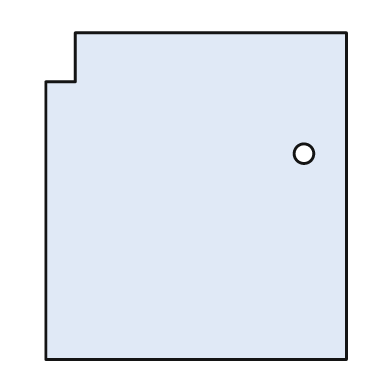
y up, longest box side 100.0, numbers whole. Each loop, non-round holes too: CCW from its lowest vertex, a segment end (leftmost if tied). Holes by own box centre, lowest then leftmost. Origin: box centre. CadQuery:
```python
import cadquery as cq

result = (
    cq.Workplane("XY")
    .moveTo(-46.0, -50.0)
    .lineTo(46.0, -50.0)
    .lineTo(46.0, 50.0)
    .lineTo(-37.0, 50.0)
    .lineTo(-37.0, 35.0)
    .lineTo(-46.0, 35.0)
    .close()
    .moveTo(33.0, 13.0)
    .circle(3.0)
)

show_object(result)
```